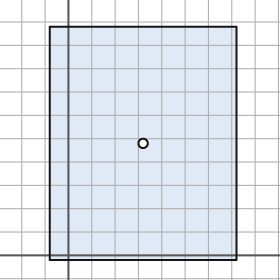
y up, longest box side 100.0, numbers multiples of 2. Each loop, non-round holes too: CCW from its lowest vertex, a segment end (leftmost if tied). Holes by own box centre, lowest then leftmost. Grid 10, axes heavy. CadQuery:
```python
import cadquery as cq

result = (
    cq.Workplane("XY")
    .moveTo(-8.0, -2.0)
    .lineTo(72.0, -2.0)
    .lineTo(72.0, 98.0)
    .lineTo(-8.0, 98.0)
    .close()
    .moveTo(32.0, 48.0)
    .circle(2.0)
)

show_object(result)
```